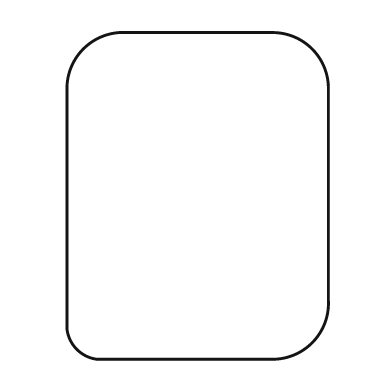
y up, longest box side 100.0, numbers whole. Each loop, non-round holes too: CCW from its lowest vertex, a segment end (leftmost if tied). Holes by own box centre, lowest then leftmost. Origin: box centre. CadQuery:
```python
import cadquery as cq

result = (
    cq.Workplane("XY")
    .moveTo(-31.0, -50.0)
    .lineTo(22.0, -50.0)
    .threePointArc((35.0, -45.0), (40.0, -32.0))
    .lineTo(40.0, 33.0)
    .threePointArc((35.0, 45.0), (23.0, 50.0))
    .lineTo(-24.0, 50.0)
    .threePointArc((-35.0, 45.0), (-40.0, 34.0))
    .lineTo(-40.0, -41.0)
    .threePointArc((-37.0, -47.0), (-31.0, -50.0))
    .close()
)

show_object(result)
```